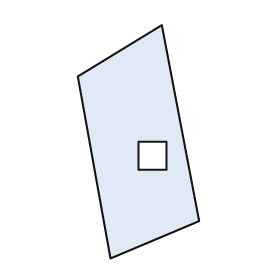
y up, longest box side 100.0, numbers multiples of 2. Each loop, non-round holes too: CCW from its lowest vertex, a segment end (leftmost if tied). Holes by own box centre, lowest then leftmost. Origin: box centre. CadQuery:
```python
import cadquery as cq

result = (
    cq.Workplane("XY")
    .moveTo(-12.0, -50.0)
    .lineTo(26.0, -34.0)
    .lineTo(10.0, 50.0)
    .lineTo(-26.0, 28.0)
    .close()
    .moveTo(0.0, -12.0)
    .lineTo(12.0, -12.0)
    .lineTo(12.0, 0.0)
    .lineTo(0.0, 0.0)
    .close()
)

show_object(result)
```